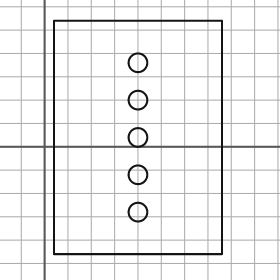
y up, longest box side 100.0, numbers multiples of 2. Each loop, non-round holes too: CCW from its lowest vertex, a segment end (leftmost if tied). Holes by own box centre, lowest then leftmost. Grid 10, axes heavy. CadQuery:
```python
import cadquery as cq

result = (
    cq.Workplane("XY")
    .moveTo(4.0, -46.0)
    .lineTo(76.0, -46.0)
    .lineTo(76.0, 54.0)
    .lineTo(4.0, 54.0)
    .close()
    .moveTo(40.0, -28.0)
    .circle(4.0)
    .moveTo(40.0, -12.0)
    .circle(4.0)
    .moveTo(40.0, 4.0)
    .circle(4.0)
    .moveTo(40.0, 20.0)
    .circle(4.0)
    .moveTo(40.0, 36.0)
    .circle(4.0)
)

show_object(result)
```